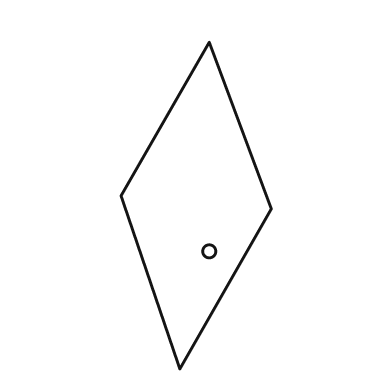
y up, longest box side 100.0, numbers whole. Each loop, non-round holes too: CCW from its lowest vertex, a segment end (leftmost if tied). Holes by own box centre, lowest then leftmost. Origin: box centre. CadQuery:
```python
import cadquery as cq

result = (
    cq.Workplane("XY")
    .moveTo(-5.0, -50.0)
    .lineTo(23.0, -1.0)
    .lineTo(4.0, 50.0)
    .lineTo(-23.0, 3.0)
    .close()
    .moveTo(4.0, -14.0)
    .circle(2.0)
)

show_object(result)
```